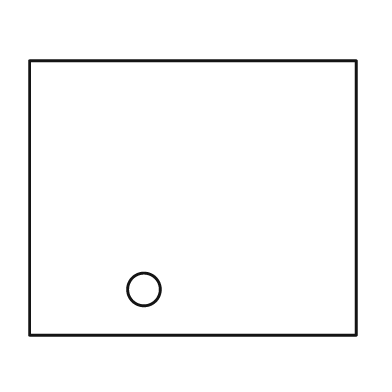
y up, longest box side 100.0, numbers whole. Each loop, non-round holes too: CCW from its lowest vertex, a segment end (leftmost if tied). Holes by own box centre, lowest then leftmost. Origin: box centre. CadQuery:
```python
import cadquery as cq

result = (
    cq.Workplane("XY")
    .moveTo(-50.0, -42.0)
    .lineTo(50.0, -42.0)
    .lineTo(50.0, 42.0)
    .lineTo(-50.0, 42.0)
    .close()
    .moveTo(-15.0, -28.0)
    .circle(5.0)
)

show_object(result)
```